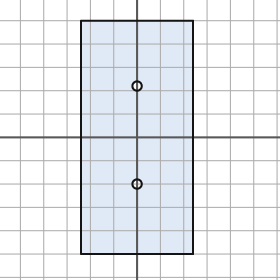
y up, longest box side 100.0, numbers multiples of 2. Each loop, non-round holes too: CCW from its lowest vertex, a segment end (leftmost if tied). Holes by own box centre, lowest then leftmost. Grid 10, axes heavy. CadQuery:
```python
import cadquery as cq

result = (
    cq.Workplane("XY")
    .moveTo(-24.0, -50.0)
    .lineTo(24.0, -50.0)
    .lineTo(24.0, 50.0)
    .lineTo(-24.0, 50.0)
    .close()
    .moveTo(0.0, -20.0)
    .circle(2.0)
    .moveTo(0.0, 22.0)
    .circle(2.0)
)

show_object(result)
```